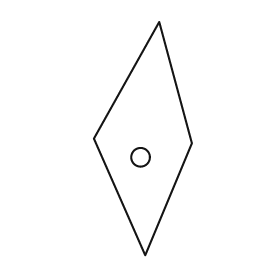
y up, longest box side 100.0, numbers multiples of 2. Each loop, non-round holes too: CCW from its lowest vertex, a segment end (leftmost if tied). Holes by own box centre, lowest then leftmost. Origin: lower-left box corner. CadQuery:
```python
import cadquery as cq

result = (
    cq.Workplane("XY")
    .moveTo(22.0, 0.0)
    .lineTo(42.0, 48.0)
    .lineTo(28.0, 100.0)
    .lineTo(0.0, 50.0)
    .close()
    .moveTo(20.0, 42.0)
    .circle(4.0)
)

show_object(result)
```